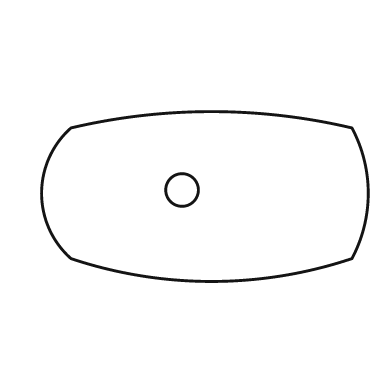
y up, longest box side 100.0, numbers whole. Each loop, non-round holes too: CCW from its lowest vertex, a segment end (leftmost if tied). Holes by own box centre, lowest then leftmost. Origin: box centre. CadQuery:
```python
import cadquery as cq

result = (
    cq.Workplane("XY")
    .moveTo(-41.0, -19.0)
    .threePointArc((2.0, -26.0), (45.0, -19.0))
    .threePointArc((50.0, 1.0), (45.0, 21.0))
    .threePointArc((2.0, 26.0), (-41.0, 21.0))
    .threePointArc((-50.0, 1.0), (-41.0, -19.0))
    .close()
    .moveTo(-7.0, 2.0)
    .circle(5.0)
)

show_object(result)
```